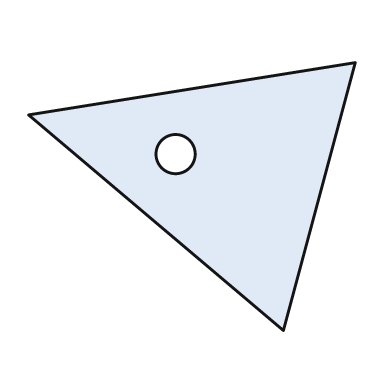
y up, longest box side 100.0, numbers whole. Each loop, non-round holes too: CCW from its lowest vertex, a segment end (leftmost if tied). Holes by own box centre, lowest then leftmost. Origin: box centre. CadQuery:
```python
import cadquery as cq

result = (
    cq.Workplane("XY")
    .moveTo(28.0, -41.0)
    .lineTo(50.0, 41.0)
    .lineTo(-50.0, 25.0)
    .close()
    .moveTo(-5.0, 13.0)
    .circle(6.0)
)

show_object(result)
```